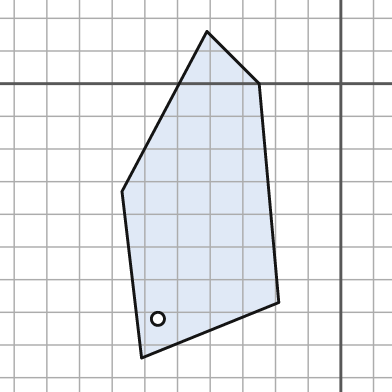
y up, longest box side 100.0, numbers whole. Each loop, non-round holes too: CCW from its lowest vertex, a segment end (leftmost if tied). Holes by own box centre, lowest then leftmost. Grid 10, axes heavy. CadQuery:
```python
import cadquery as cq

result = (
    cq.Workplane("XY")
    .moveTo(-61.0, -84.0)
    .lineTo(-19.0, -67.0)
    .lineTo(-25.0, 0.0)
    .lineTo(-41.0, 16.0)
    .lineTo(-67.0, -33.0)
    .close()
    .moveTo(-56.0, -72.0)
    .circle(2.0)
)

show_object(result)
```